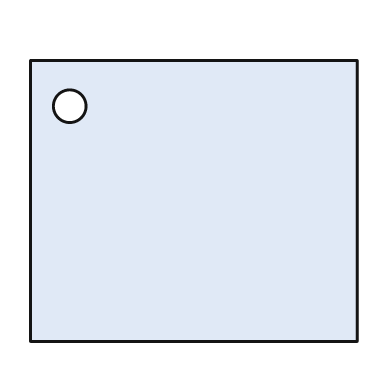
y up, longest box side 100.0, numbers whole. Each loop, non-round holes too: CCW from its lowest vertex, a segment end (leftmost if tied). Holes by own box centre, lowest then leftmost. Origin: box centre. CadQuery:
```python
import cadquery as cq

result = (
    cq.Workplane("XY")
    .moveTo(-50.0, -43.0)
    .lineTo(50.0, -43.0)
    .lineTo(50.0, 43.0)
    .lineTo(-50.0, 43.0)
    .close()
    .moveTo(-38.0, 29.0)
    .circle(5.0)
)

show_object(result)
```